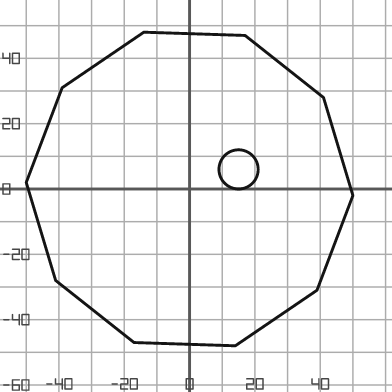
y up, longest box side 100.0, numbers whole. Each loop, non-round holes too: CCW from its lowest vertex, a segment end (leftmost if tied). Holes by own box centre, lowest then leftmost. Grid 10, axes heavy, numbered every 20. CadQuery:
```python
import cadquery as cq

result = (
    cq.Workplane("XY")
    .moveTo(14.0, -48.0)
    .lineTo(39.0, -31.0)
    .lineTo(50.0, -2.0)
    .lineTo(41.0, 28.0)
    .lineTo(17.0, 47.0)
    .lineTo(-14.0, 48.0)
    .lineTo(-39.0, 31.0)
    .lineTo(-50.0, 2.0)
    .lineTo(-41.0, -28.0)
    .lineTo(-17.0, -47.0)
    .close()
    .moveTo(15.0, 6.0)
    .circle(6.0)
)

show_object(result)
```